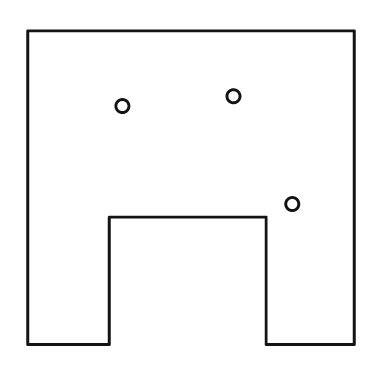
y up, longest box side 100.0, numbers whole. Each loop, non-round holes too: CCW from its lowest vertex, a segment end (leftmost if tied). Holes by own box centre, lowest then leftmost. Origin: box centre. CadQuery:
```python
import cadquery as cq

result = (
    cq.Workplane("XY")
    .moveTo(-50.0, -48.0)
    .lineTo(-25.0, -48.0)
    .lineTo(-25.0, -9.0)
    .lineTo(23.0, -9.0)
    .lineTo(23.0, -48.0)
    .lineTo(50.0, -48.0)
    .lineTo(50.0, 48.0)
    .lineTo(-50.0, 48.0)
    .close()
    .moveTo(31.0, -5.0)
    .circle(2.0)
    .moveTo(-21.0, 25.0)
    .circle(2.0)
    .moveTo(13.0, 28.0)
    .circle(2.0)
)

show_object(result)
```